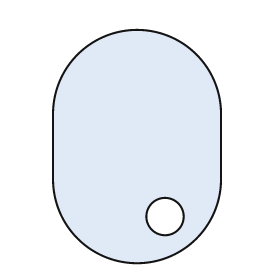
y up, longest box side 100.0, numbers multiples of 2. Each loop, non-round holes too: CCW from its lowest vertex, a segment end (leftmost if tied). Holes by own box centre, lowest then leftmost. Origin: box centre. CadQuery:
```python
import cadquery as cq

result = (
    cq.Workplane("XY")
    .moveTo(-36.0, -14.0)
    .threePointArc((0.0, -50.0), (36.0, -14.0))
    .lineTo(36.0, 14.0)
    .threePointArc((0.0, 50.0), (-36.0, 14.0))
    .close()
    .moveTo(12.0, -30.0)
    .circle(8.0)
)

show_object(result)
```